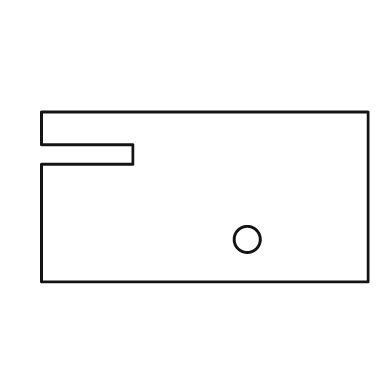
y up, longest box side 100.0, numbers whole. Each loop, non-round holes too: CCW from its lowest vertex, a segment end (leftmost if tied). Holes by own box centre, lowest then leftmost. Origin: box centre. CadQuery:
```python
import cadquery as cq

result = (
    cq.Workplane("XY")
    .moveTo(-50.0, -26.0)
    .lineTo(50.0, -26.0)
    .lineTo(50.0, 26.0)
    .lineTo(-50.0, 26.0)
    .lineTo(-50.0, 16.0)
    .lineTo(-22.0, 16.0)
    .lineTo(-22.0, 10.0)
    .lineTo(-50.0, 10.0)
    .close()
    .moveTo(13.0, -13.0)
    .circle(4.0)
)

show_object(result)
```